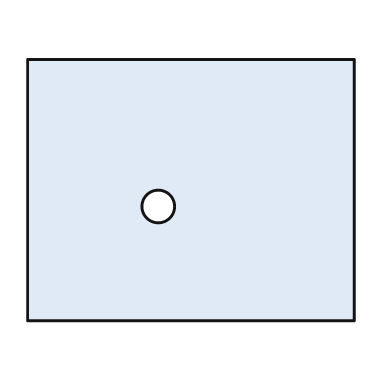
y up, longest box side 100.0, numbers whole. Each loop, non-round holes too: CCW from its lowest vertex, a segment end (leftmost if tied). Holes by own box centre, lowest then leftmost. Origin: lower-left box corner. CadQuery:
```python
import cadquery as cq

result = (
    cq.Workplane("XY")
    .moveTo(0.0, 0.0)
    .lineTo(100.0, 0.0)
    .lineTo(100.0, 80.0)
    .lineTo(0.0, 80.0)
    .close()
    .moveTo(40.0, 35.0)
    .circle(5.0)
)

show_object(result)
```